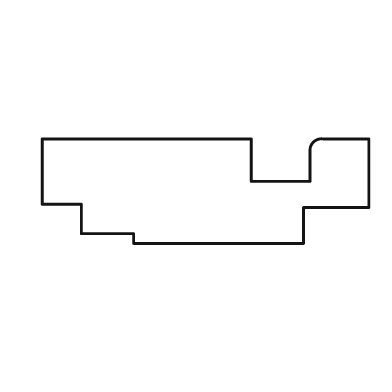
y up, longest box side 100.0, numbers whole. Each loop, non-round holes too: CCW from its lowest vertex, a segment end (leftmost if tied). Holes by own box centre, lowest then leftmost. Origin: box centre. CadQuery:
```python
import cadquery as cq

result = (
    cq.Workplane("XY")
    .moveTo(-22.0, -16.0)
    .lineTo(30.0, -16.0)
    .lineTo(30.0, -5.0)
    .lineTo(50.0, -5.0)
    .lineTo(50.0, 16.0)
    .lineTo(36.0, 16.0)
    .threePointArc((33.0, 15.0), (32.0, 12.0))
    .lineTo(32.0, 3.0)
    .lineTo(14.0, 3.0)
    .lineTo(14.0, 16.0)
    .lineTo(-50.0, 16.0)
    .lineTo(-50.0, -4.0)
    .lineTo(-38.0, -4.0)
    .lineTo(-38.0, -13.0)
    .lineTo(-22.0, -13.0)
    .close()
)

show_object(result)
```